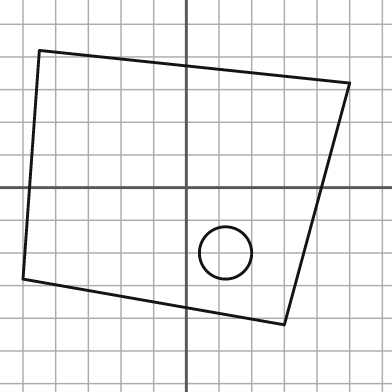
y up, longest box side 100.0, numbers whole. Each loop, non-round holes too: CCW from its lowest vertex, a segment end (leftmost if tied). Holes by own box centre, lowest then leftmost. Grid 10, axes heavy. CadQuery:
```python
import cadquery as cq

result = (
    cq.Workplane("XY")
    .moveTo(30.0, -42.0)
    .lineTo(50.0, 32.0)
    .lineTo(-45.0, 42.0)
    .lineTo(-50.0, -28.0)
    .close()
    .moveTo(12.0, -20.0)
    .circle(8.0)
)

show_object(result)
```